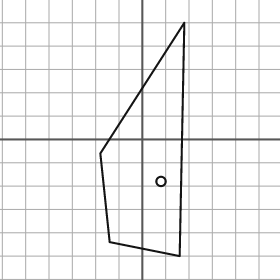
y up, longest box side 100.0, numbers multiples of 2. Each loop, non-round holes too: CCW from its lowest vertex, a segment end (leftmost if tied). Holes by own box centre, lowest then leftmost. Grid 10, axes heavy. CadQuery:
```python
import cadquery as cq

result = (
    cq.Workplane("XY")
    .moveTo(16.0, -50.0)
    .lineTo(18.0, 50.0)
    .lineTo(-18.0, -6.0)
    .lineTo(-14.0, -44.0)
    .close()
    .moveTo(8.0, -18.0)
    .circle(2.0)
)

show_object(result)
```